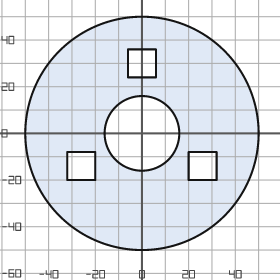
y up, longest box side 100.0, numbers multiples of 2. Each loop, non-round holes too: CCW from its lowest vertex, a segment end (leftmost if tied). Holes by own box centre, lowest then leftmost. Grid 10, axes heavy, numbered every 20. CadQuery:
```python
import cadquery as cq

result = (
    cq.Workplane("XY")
    .moveTo(0.0, 0.0)
    .circle(50.0)
    .moveTo(-32.0, -20.0)
    .lineTo(-20.0, -20.0)
    .lineTo(-20.0, -8.0)
    .lineTo(-32.0, -8.0)
    .close()
    .moveTo(20.0, -20.0)
    .lineTo(32.0, -20.0)
    .lineTo(32.0, -8.0)
    .lineTo(20.0, -8.0)
    .close()
    .moveTo(0.0, 0.0)
    .circle(16.0)
    .moveTo(-6.0, 24.0)
    .lineTo(6.0, 24.0)
    .lineTo(6.0, 36.0)
    .lineTo(-6.0, 36.0)
    .close()
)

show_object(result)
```